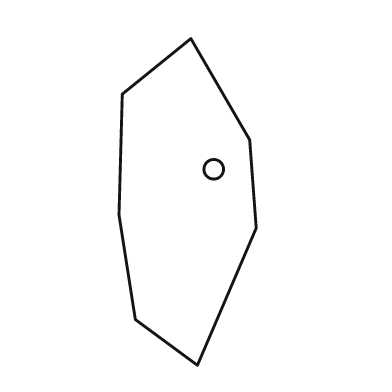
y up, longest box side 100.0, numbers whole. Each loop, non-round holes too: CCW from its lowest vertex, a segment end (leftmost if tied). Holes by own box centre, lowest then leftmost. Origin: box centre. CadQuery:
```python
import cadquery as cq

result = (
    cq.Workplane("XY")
    .moveTo(3.0, -50.0)
    .lineTo(21.0, -8.0)
    .lineTo(19.0, 19.0)
    .lineTo(1.0, 50.0)
    .lineTo(-20.0, 33.0)
    .lineTo(-21.0, -4.0)
    .lineTo(-16.0, -36.0)
    .close()
    .moveTo(8.0, 10.0)
    .circle(3.0)
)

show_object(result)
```